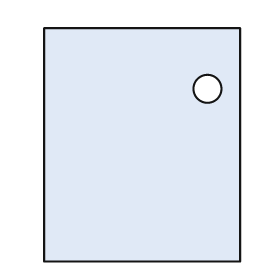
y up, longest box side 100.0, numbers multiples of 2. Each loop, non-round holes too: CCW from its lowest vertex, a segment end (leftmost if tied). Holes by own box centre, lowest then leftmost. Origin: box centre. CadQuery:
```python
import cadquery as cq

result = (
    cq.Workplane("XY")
    .moveTo(-42.0, -50.0)
    .lineTo(42.0, -50.0)
    .lineTo(42.0, 50.0)
    .lineTo(-42.0, 50.0)
    .close()
    .moveTo(28.0, 24.0)
    .circle(6.0)
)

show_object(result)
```